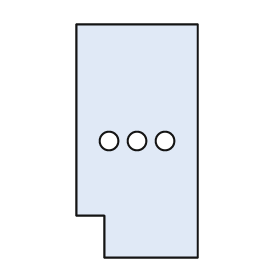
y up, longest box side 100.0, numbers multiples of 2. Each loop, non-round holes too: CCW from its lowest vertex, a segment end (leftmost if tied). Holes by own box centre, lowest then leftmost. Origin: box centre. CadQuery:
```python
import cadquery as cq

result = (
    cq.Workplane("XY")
    .moveTo(-14.0, -50.0)
    .lineTo(26.0, -50.0)
    .lineTo(26.0, 50.0)
    .lineTo(-26.0, 50.0)
    .lineTo(-26.0, -32.0)
    .lineTo(-14.0, -32.0)
    .close()
    .moveTo(-12.0, 0.0)
    .circle(4.0)
    .moveTo(0.0, 0.0)
    .circle(4.0)
    .moveTo(12.0, 0.0)
    .circle(4.0)
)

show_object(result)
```